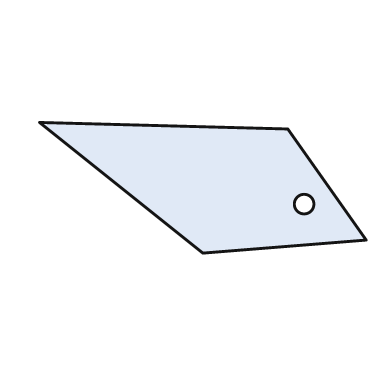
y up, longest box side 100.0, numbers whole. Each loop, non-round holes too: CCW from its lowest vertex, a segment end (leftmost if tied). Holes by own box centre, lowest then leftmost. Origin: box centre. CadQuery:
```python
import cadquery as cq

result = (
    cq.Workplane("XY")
    .moveTo(0.0, -20.0)
    .lineTo(50.0, -16.0)
    .lineTo(26.0, 18.0)
    .lineTo(-50.0, 20.0)
    .close()
    .moveTo(31.0, -5.0)
    .circle(3.0)
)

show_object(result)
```